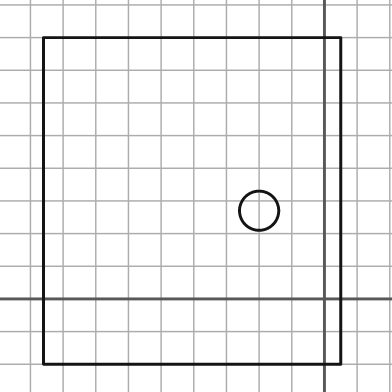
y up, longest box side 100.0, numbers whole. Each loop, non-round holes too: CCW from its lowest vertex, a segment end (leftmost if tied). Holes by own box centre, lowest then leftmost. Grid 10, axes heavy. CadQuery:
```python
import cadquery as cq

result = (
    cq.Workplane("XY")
    .moveTo(-86.0, -20.0)
    .lineTo(5.0, -20.0)
    .lineTo(5.0, 80.0)
    .lineTo(-86.0, 80.0)
    .close()
    .moveTo(-20.0, 27.0)
    .circle(6.0)
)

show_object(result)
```